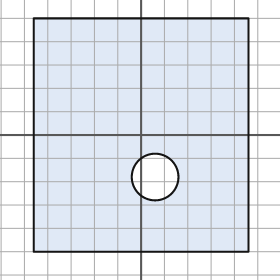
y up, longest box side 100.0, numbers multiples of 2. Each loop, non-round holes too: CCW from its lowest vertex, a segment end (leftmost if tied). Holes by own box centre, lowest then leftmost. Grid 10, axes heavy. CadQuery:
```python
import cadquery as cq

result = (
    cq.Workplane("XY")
    .moveTo(-46.0, -50.0)
    .lineTo(46.0, -50.0)
    .lineTo(46.0, 50.0)
    .lineTo(-46.0, 50.0)
    .close()
    .moveTo(6.0, -18.0)
    .circle(10.0)
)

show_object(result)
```